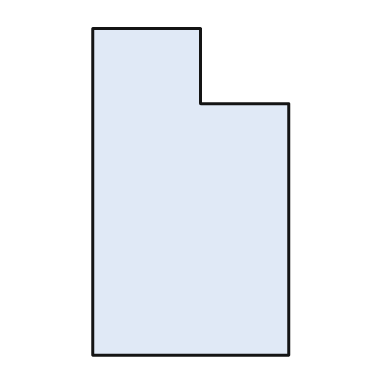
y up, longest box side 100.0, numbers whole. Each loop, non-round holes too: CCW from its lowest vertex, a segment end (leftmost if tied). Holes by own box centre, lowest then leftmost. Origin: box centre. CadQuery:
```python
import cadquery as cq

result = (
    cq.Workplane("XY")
    .moveTo(-30.0, -50.0)
    .lineTo(30.0, -50.0)
    .lineTo(30.0, 27.0)
    .lineTo(3.0, 27.0)
    .lineTo(3.0, 50.0)
    .lineTo(-30.0, 50.0)
    .close()
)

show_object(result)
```